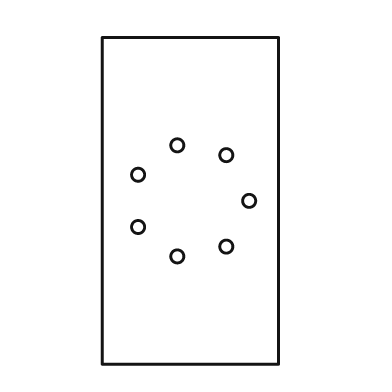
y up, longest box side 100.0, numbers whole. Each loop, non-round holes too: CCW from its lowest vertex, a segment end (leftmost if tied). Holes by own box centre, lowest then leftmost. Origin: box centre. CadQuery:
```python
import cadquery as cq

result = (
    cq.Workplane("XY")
    .moveTo(-27.0, -50.0)
    .lineTo(27.0, -50.0)
    .lineTo(27.0, 50.0)
    .lineTo(-27.0, 50.0)
    .close()
    .moveTo(-4.0, -17.0)
    .circle(2.0)
    .moveTo(11.0, -14.0)
    .circle(2.0)
    .moveTo(-16.0, -8.0)
    .circle(2.0)
    .moveTo(18.0, 0.0)
    .circle(2.0)
    .moveTo(-16.0, 8.0)
    .circle(2.0)
    .moveTo(11.0, 14.0)
    .circle(2.0)
    .moveTo(-4.0, 17.0)
    .circle(2.0)
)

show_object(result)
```